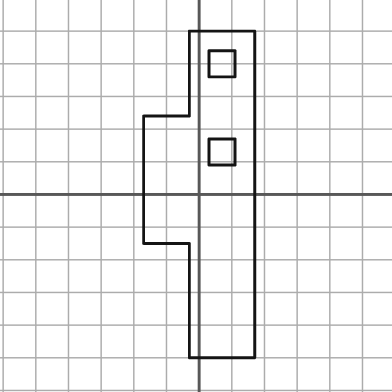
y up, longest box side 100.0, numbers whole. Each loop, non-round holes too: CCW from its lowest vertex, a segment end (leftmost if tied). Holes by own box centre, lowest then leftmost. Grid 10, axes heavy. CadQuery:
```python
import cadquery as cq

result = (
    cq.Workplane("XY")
    .moveTo(-3.0, -50.0)
    .lineTo(17.0, -50.0)
    .lineTo(17.0, 50.0)
    .lineTo(-3.0, 50.0)
    .lineTo(-3.0, 24.0)
    .lineTo(-17.0, 24.0)
    .lineTo(-17.0, -15.0)
    .lineTo(-3.0, -15.0)
    .close()
    .moveTo(3.0, 9.0)
    .lineTo(11.0, 9.0)
    .lineTo(11.0, 17.0)
    .lineTo(3.0, 17.0)
    .close()
    .moveTo(3.0, 36.0)
    .lineTo(11.0, 36.0)
    .lineTo(11.0, 44.0)
    .lineTo(3.0, 44.0)
    .close()
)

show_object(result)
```